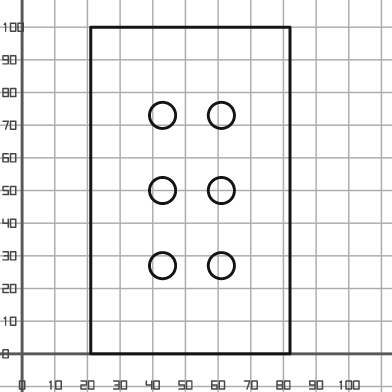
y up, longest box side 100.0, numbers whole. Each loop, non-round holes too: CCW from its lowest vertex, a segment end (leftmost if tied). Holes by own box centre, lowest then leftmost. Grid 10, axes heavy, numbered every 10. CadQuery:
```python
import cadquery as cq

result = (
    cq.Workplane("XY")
    .moveTo(21.0, 0.0)
    .lineTo(82.0, 0.0)
    .lineTo(82.0, 100.0)
    .lineTo(21.0, 100.0)
    .close()
    .moveTo(43.0, 27.0)
    .circle(4.0)
    .moveTo(61.0, 27.0)
    .circle(4.0)
    .moveTo(43.0, 50.0)
    .circle(4.0)
    .moveTo(61.0, 50.0)
    .circle(4.0)
    .moveTo(43.0, 73.0)
    .circle(4.0)
    .moveTo(61.0, 73.0)
    .circle(4.0)
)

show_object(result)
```